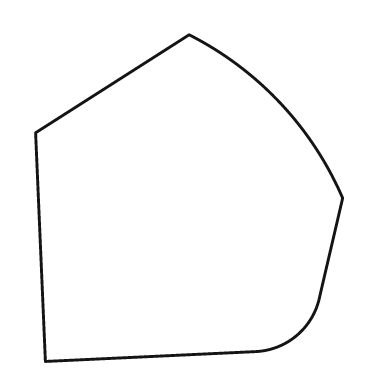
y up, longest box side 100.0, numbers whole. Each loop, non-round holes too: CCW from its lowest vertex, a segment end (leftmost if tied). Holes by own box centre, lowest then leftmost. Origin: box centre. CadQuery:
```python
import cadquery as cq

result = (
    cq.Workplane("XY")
    .moveTo(-44.0, -50.0)
    .lineTo(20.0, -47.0)
    .threePointArc((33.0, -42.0), (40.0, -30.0))
    .lineTo(47.0, 0.0)
    .threePointArc((28.0, 29.0), (0.0, 50.0))
    .lineTo(-47.0, 20.0)
    .close()
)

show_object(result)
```